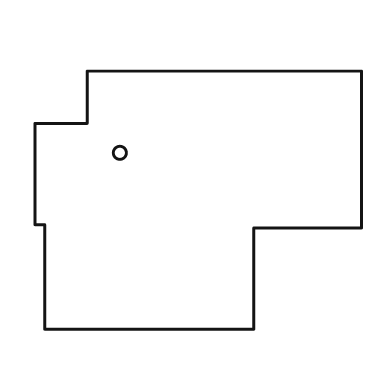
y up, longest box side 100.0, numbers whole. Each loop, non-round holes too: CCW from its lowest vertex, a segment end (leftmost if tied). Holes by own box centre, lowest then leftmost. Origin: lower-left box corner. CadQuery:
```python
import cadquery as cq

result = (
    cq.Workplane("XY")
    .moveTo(3.0, 0.0)
    .lineTo(67.0, 0.0)
    .lineTo(67.0, 31.0)
    .lineTo(100.0, 31.0)
    .lineTo(100.0, 79.0)
    .lineTo(16.0, 79.0)
    .lineTo(16.0, 63.0)
    .lineTo(0.0, 63.0)
    .lineTo(0.0, 32.0)
    .lineTo(3.0, 32.0)
    .close()
    .moveTo(26.0, 54.0)
    .circle(2.0)
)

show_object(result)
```